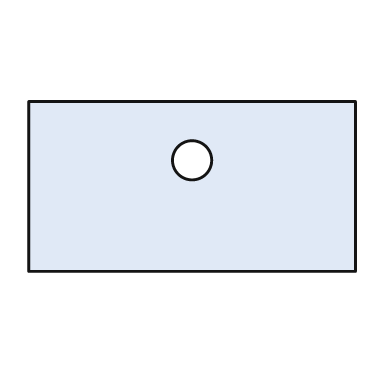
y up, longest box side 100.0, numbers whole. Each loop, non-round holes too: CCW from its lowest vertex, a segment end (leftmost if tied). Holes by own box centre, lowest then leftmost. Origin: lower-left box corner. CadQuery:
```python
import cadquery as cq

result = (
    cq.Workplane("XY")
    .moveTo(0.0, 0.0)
    .lineTo(100.0, 0.0)
    .lineTo(100.0, 52.0)
    .lineTo(0.0, 52.0)
    .close()
    .moveTo(50.0, 34.0)
    .circle(6.0)
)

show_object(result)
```